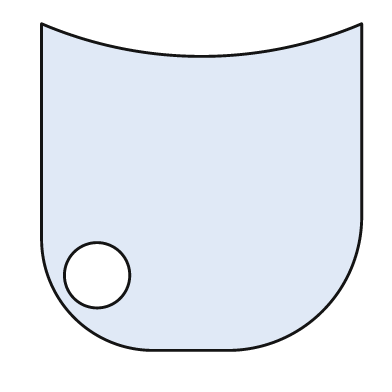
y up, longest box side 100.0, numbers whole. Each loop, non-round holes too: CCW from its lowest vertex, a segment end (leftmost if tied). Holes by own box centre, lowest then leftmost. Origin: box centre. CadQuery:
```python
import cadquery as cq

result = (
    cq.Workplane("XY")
    .moveTo(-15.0, -50.0)
    .lineTo(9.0, -50.0)
    .threePointArc((37.0, -38.0), (49.0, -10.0))
    .lineTo(49.0, 50.0)
    .threePointArc((0.0, 40.0), (-49.0, 50.0))
    .lineTo(-49.0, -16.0)
    .threePointArc((-39.0, -40.0), (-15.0, -50.0))
    .close()
    .moveTo(-32.0, -27.0)
    .circle(10.0)
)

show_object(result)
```